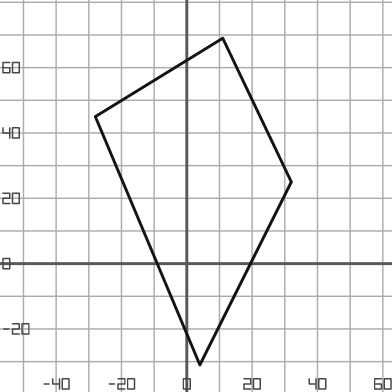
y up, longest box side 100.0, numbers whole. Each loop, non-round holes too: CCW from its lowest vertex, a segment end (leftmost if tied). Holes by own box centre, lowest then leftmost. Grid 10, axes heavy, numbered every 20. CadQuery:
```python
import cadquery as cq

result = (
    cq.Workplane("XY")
    .moveTo(4.0, -31.0)
    .lineTo(32.0, 25.0)
    .lineTo(11.0, 69.0)
    .lineTo(-28.0, 45.0)
    .close()
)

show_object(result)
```